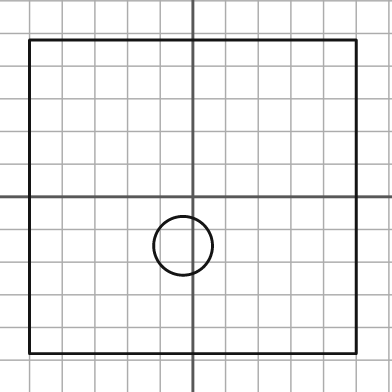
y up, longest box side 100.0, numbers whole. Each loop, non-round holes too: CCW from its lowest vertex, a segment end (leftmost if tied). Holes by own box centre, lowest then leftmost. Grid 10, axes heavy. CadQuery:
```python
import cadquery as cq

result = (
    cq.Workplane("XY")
    .moveTo(-50.0, -48.0)
    .lineTo(50.0, -48.0)
    .lineTo(50.0, 48.0)
    .lineTo(-50.0, 48.0)
    .close()
    .moveTo(-3.0, -15.0)
    .circle(9.0)
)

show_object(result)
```